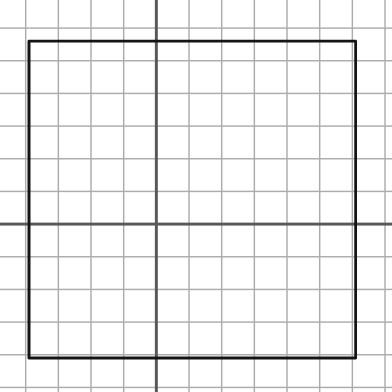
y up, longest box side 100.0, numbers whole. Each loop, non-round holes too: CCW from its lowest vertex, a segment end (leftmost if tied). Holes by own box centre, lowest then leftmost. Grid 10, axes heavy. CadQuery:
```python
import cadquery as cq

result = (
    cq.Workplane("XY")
    .moveTo(-39.0, -41.0)
    .lineTo(61.0, -41.0)
    .lineTo(61.0, 56.0)
    .lineTo(-39.0, 56.0)
    .close()
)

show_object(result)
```